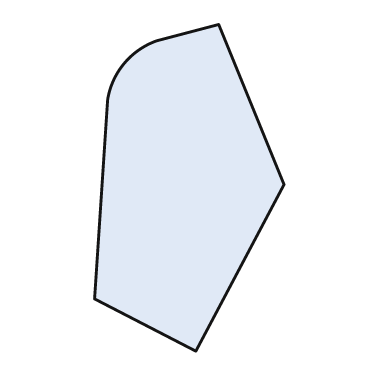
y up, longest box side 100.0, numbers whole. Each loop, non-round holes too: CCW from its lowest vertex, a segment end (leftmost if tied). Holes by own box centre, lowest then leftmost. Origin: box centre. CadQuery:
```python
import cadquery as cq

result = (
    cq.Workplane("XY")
    .moveTo(2.0, -50.0)
    .lineTo(29.0, 1.0)
    .lineTo(9.0, 50.0)
    .lineTo(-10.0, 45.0)
    .threePointArc((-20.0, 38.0), (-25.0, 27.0))
    .lineTo(-29.0, -34.0)
    .close()
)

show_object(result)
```